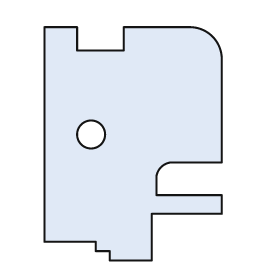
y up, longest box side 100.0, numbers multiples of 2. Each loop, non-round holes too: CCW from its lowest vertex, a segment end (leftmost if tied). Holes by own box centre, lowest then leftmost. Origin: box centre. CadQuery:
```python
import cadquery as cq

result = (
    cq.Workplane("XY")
    .moveTo(-10.0, -50.0)
    .lineTo(8.0, -50.0)
    .lineTo(8.0, -30.0)
    .lineTo(38.0, -30.0)
    .lineTo(38.0, -22.0)
    .lineTo(10.0, -22.0)
    .lineTo(10.0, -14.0)
    .threePointArc((12.0, -10.0), (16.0, -8.0))
    .lineTo(38.0, -8.0)
    .lineTo(38.0, 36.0)
    .threePointArc((34.0, 46.0), (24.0, 50.0))
    .lineTo(-4.0, 50.0)
    .lineTo(-4.0, 40.0)
    .lineTo(-24.0, 40.0)
    .lineTo(-24.0, 50.0)
    .lineTo(-38.0, 50.0)
    .lineTo(-38.0, -42.0)
    .lineTo(-16.0, -42.0)
    .lineTo(-16.0, -46.0)
    .lineTo(-10.0, -46.0)
    .close()
    .moveTo(-18.0, 4.0)
    .circle(6.0)
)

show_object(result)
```